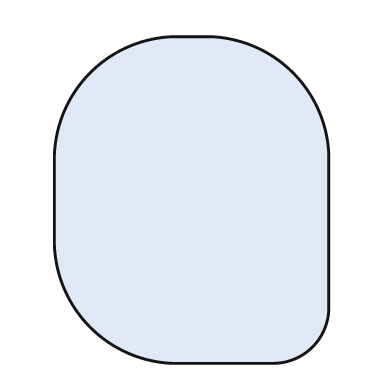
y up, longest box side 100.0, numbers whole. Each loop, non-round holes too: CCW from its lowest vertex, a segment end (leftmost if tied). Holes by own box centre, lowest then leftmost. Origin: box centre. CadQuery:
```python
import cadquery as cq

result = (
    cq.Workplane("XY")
    .moveTo(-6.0, -50.0)
    .lineTo(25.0, -50.0)
    .threePointArc((37.0, -45.0), (42.0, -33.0))
    .lineTo(42.0, 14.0)
    .threePointArc((31.0, 39.0), (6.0, 50.0))
    .lineTo(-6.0, 50.0)
    .threePointArc((-31.0, 39.0), (-42.0, 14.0))
    .lineTo(-42.0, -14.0)
    .threePointArc((-31.0, -39.0), (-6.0, -50.0))
    .close()
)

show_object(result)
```